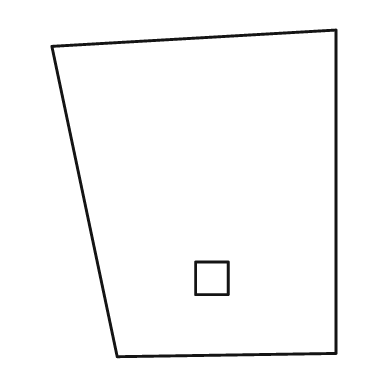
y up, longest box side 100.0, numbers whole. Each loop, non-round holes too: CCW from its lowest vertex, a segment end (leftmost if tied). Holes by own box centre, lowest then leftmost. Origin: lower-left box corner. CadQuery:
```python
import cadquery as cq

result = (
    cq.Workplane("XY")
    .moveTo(20.0, 0.0)
    .lineTo(87.0, 1.0)
    .lineTo(87.0, 100.0)
    .lineTo(0.0, 95.0)
    .close()
    .moveTo(44.0, 19.0)
    .lineTo(54.0, 19.0)
    .lineTo(54.0, 29.0)
    .lineTo(44.0, 29.0)
    .close()
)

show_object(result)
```